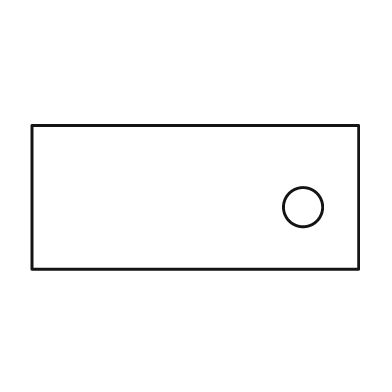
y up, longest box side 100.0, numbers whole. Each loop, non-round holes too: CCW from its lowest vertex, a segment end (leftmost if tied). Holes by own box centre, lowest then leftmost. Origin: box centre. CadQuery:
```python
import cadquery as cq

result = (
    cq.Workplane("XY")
    .moveTo(-50.0, -22.0)
    .lineTo(50.0, -22.0)
    .lineTo(50.0, 22.0)
    .lineTo(-50.0, 22.0)
    .close()
    .moveTo(33.0, -3.0)
    .circle(6.0)
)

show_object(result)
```